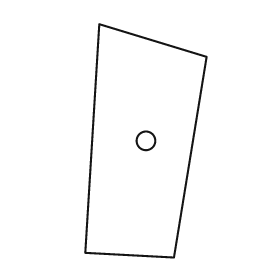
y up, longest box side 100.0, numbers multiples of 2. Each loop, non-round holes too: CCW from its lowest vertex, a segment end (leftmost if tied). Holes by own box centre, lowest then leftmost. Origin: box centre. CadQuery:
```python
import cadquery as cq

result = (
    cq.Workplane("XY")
    .moveTo(12.0, -50.0)
    .lineTo(26.0, 36.0)
    .lineTo(-20.0, 50.0)
    .lineTo(-26.0, -48.0)
    .close()
    .moveTo(0.0, 0.0)
    .circle(4.0)
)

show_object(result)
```